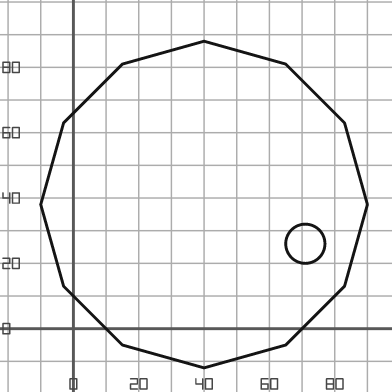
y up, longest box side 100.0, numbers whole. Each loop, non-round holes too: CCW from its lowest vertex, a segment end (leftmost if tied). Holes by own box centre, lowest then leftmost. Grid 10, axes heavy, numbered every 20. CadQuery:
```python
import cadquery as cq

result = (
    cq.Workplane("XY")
    .moveTo(40.0, -12.0)
    .lineTo(65.0, -5.0)
    .lineTo(83.0, 13.0)
    .lineTo(90.0, 38.0)
    .lineTo(83.0, 63.0)
    .lineTo(65.0, 81.0)
    .lineTo(40.0, 88.0)
    .lineTo(15.0, 81.0)
    .lineTo(-3.0, 63.0)
    .lineTo(-10.0, 38.0)
    .lineTo(-3.0, 13.0)
    .lineTo(15.0, -5.0)
    .close()
    .moveTo(71.0, 26.0)
    .circle(6.0)
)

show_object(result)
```